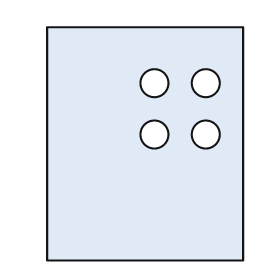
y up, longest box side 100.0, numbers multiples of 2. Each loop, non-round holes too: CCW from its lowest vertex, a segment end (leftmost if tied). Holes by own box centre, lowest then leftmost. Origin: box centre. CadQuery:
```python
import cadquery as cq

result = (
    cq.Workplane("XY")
    .moveTo(-42.0, -50.0)
    .lineTo(42.0, -50.0)
    .lineTo(42.0, 50.0)
    .lineTo(-42.0, 50.0)
    .close()
    .moveTo(4.0, 4.0)
    .circle(6.0)
    .moveTo(26.0, 4.0)
    .circle(6.0)
    .moveTo(4.0, 26.0)
    .circle(6.0)
    .moveTo(26.0, 26.0)
    .circle(6.0)
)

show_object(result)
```